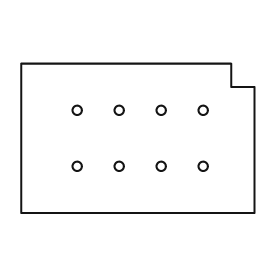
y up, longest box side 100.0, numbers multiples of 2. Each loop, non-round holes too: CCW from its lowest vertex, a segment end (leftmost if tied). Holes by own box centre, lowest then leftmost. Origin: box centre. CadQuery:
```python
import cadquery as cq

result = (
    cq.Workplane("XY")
    .moveTo(-50.0, -32.0)
    .lineTo(50.0, -32.0)
    .lineTo(50.0, 22.0)
    .lineTo(40.0, 22.0)
    .lineTo(40.0, 32.0)
    .lineTo(-50.0, 32.0)
    .close()
    .moveTo(-26.0, -12.0)
    .circle(2.0)
    .moveTo(-8.0, -12.0)
    .circle(2.0)
    .moveTo(10.0, -12.0)
    .circle(2.0)
    .moveTo(28.0, -12.0)
    .circle(2.0)
    .moveTo(-26.0, 12.0)
    .circle(2.0)
    .moveTo(-8.0, 12.0)
    .circle(2.0)
    .moveTo(10.0, 12.0)
    .circle(2.0)
    .moveTo(28.0, 12.0)
    .circle(2.0)
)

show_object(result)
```